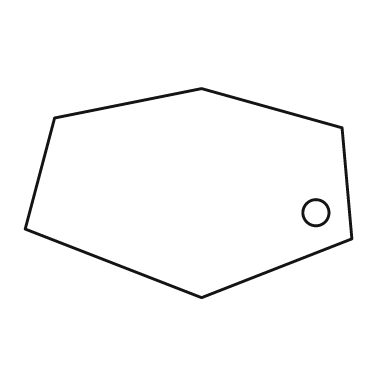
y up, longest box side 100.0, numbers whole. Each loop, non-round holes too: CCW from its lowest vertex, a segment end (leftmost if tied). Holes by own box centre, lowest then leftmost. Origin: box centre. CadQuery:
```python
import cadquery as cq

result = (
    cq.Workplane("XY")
    .moveTo(4.0, -32.0)
    .lineTo(50.0, -14.0)
    .lineTo(47.0, 20.0)
    .lineTo(4.0, 32.0)
    .lineTo(-41.0, 23.0)
    .lineTo(-50.0, -11.0)
    .close()
    .moveTo(39.0, -6.0)
    .circle(4.0)
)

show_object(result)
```